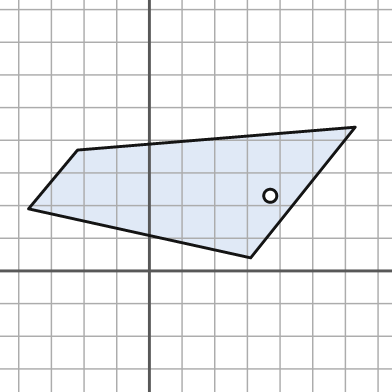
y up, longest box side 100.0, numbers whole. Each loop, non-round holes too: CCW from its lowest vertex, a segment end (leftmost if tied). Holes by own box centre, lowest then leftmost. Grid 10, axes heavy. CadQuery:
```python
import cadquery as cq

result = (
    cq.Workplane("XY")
    .moveTo(31.0, 4.0)
    .lineTo(63.0, 44.0)
    .lineTo(-22.0, 37.0)
    .lineTo(-37.0, 19.0)
    .close()
    .moveTo(37.0, 23.0)
    .circle(2.0)
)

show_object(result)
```